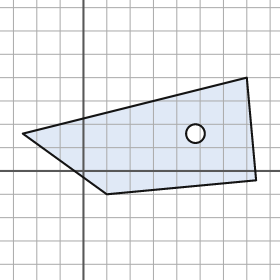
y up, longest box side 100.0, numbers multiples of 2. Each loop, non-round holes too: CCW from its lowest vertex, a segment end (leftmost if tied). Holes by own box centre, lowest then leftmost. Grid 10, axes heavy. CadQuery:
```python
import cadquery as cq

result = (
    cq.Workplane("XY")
    .moveTo(10.0, -10.0)
    .lineTo(74.0, -4.0)
    .lineTo(70.0, 40.0)
    .lineTo(-26.0, 16.0)
    .close()
    .moveTo(48.0, 16.0)
    .circle(4.0)
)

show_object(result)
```